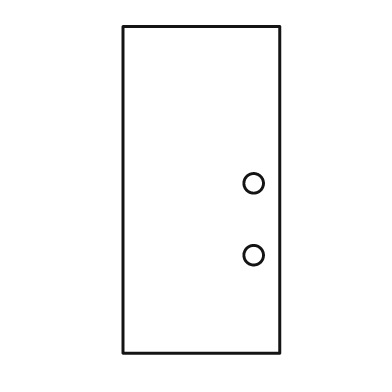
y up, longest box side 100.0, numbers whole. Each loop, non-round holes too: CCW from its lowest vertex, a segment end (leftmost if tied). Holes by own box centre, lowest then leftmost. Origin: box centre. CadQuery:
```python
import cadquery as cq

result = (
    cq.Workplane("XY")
    .moveTo(-24.0, -50.0)
    .lineTo(24.0, -50.0)
    .lineTo(24.0, 50.0)
    .lineTo(-24.0, 50.0)
    .close()
    .moveTo(16.0, -20.0)
    .circle(3.0)
    .moveTo(16.0, 2.0)
    .circle(3.0)
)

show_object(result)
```